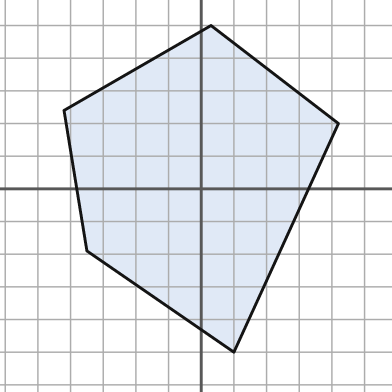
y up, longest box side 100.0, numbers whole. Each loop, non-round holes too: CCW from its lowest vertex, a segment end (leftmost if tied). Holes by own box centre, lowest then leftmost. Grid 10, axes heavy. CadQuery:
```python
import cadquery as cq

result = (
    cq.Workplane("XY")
    .moveTo(10.0, -50.0)
    .lineTo(42.0, 20.0)
    .lineTo(3.0, 50.0)
    .lineTo(-42.0, 24.0)
    .lineTo(-35.0, -19.0)
    .close()
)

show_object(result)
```